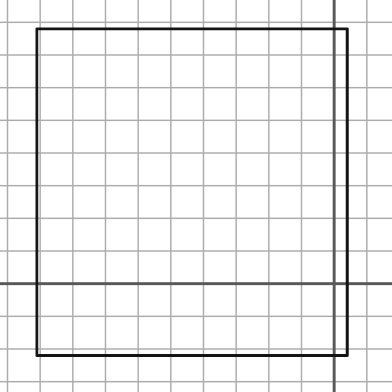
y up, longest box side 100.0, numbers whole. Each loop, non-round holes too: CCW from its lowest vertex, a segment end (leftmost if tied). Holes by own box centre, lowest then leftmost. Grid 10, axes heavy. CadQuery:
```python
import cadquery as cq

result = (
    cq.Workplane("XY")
    .moveTo(-91.0, -22.0)
    .lineTo(4.0, -22.0)
    .lineTo(4.0, 78.0)
    .lineTo(-91.0, 78.0)
    .close()
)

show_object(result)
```